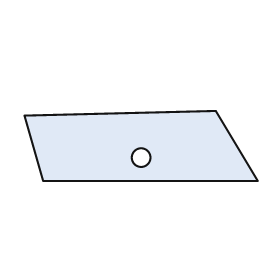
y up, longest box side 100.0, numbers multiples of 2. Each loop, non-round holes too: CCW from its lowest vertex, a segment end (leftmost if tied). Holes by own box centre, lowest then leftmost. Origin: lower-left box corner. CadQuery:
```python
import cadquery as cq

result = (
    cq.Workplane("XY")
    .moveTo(8.0, 0.0)
    .lineTo(100.0, 0.0)
    .lineTo(82.0, 30.0)
    .lineTo(0.0, 28.0)
    .close()
    .moveTo(50.0, 10.0)
    .circle(4.0)
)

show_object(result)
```